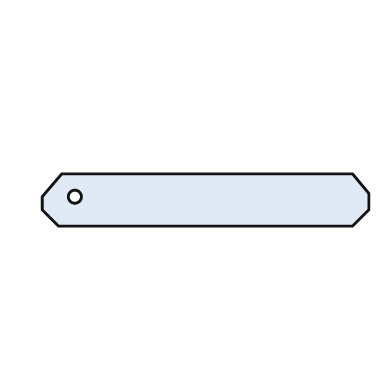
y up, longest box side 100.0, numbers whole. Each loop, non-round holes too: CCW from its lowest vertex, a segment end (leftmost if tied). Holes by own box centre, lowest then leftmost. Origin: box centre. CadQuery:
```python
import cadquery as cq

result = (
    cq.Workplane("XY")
    .moveTo(-45.0, -8.0)
    .lineTo(45.0, -8.0)
    .lineTo(50.0, -3.0)
    .lineTo(50.0, 2.0)
    .lineTo(45.0, 8.0)
    .lineTo(-44.0, 8.0)
    .lineTo(-50.0, 1.0)
    .lineTo(-50.0, -3.0)
    .close()
    .moveTo(-40.0, 1.0)
    .circle(2.0)
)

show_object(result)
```